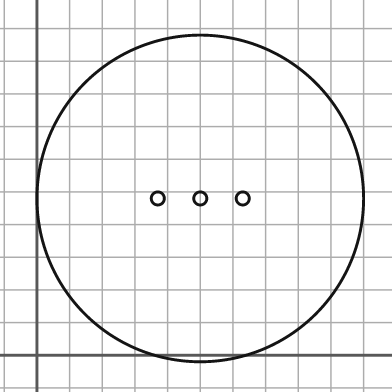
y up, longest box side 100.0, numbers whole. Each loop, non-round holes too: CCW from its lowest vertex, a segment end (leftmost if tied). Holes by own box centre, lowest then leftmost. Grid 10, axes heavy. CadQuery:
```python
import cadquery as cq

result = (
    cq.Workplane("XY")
    .moveTo(50.0, 48.0)
    .circle(50.0)
    .moveTo(37.0, 48.0)
    .circle(2.0)
    .moveTo(50.0, 48.0)
    .circle(2.0)
    .moveTo(63.0, 48.0)
    .circle(2.0)
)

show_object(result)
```